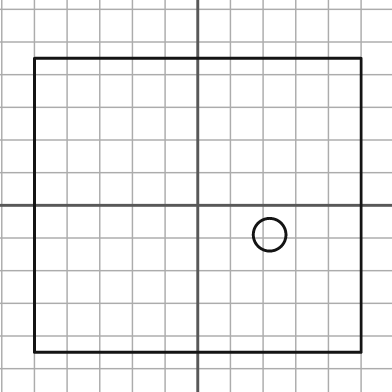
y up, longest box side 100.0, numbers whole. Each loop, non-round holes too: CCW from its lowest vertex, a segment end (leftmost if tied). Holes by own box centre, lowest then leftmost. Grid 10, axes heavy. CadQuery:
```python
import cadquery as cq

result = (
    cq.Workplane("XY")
    .moveTo(-50.0, -45.0)
    .lineTo(50.0, -45.0)
    .lineTo(50.0, 45.0)
    .lineTo(-50.0, 45.0)
    .close()
    .moveTo(22.0, -9.0)
    .circle(5.0)
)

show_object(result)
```